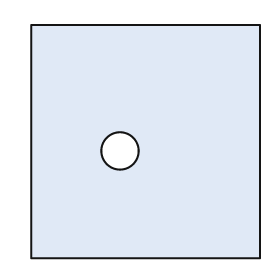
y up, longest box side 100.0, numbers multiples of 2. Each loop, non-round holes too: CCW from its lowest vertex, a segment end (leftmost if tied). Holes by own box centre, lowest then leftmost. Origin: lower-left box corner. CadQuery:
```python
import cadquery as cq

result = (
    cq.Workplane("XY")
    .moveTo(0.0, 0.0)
    .lineTo(98.0, 0.0)
    .lineTo(98.0, 100.0)
    .lineTo(0.0, 100.0)
    .close()
    .moveTo(38.0, 46.0)
    .circle(8.0)
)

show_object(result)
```